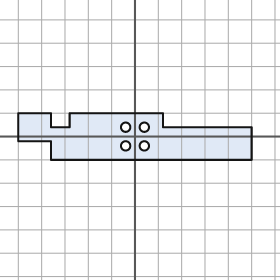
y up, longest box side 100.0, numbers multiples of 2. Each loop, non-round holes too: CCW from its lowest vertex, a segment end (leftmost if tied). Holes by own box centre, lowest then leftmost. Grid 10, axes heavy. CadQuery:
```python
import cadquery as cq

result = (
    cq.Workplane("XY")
    .moveTo(-36.0, -10.0)
    .lineTo(50.0, -10.0)
    .lineTo(50.0, 4.0)
    .lineTo(12.0, 4.0)
    .lineTo(12.0, 10.0)
    .lineTo(-28.0, 10.0)
    .lineTo(-28.0, 4.0)
    .lineTo(-36.0, 4.0)
    .lineTo(-36.0, 10.0)
    .lineTo(-50.0, 10.0)
    .lineTo(-50.0, -2.0)
    .lineTo(-36.0, -2.0)
    .close()
    .moveTo(-4.0, -4.0)
    .circle(2.0)
    .moveTo(4.0, -4.0)
    .circle(2.0)
    .moveTo(-4.0, 4.0)
    .circle(2.0)
    .moveTo(4.0, 4.0)
    .circle(2.0)
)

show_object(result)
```